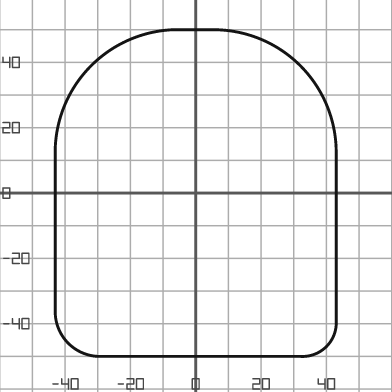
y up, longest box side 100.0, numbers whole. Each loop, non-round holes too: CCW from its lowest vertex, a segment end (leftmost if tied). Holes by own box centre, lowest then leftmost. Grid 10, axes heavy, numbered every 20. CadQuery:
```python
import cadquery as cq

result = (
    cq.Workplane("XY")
    .moveTo(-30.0, -50.0)
    .lineTo(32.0, -50.0)
    .threePointArc((40.0, -47.0), (43.0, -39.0))
    .lineTo(43.0, 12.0)
    .threePointArc((32.0, 39.0), (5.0, 50.0))
    .lineTo(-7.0, 50.0)
    .threePointArc((-32.0, 39.0), (-43.0, 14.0))
    .lineTo(-43.0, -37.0)
    .threePointArc((-39.0, -46.0), (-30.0, -50.0))
    .close()
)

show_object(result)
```